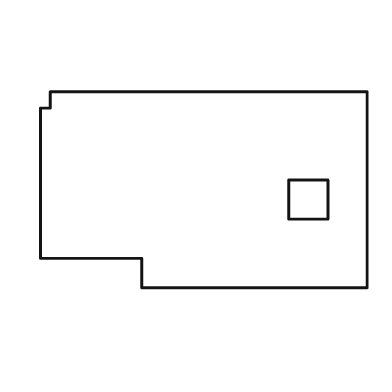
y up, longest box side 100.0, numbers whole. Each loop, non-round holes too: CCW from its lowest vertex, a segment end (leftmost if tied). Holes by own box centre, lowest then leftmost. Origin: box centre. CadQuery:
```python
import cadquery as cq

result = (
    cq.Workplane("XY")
    .moveTo(-19.0, -30.0)
    .lineTo(50.0, -30.0)
    .lineTo(50.0, 30.0)
    .lineTo(-47.0, 30.0)
    .lineTo(-47.0, 25.0)
    .lineTo(-50.0, 25.0)
    .lineTo(-50.0, -21.0)
    .lineTo(-19.0, -21.0)
    .close()
    .moveTo(26.0, -9.0)
    .lineTo(38.0, -9.0)
    .lineTo(38.0, 3.0)
    .lineTo(26.0, 3.0)
    .close()
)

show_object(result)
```